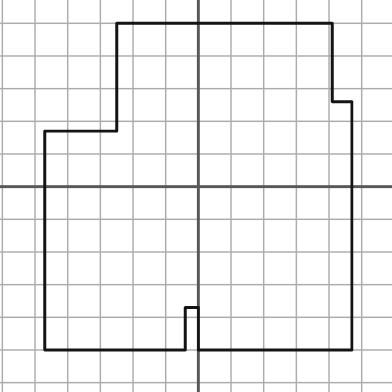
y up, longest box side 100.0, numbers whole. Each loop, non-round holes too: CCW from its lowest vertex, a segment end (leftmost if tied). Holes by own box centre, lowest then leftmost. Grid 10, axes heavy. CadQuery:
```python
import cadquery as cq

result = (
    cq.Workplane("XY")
    .moveTo(-47.0, -50.0)
    .lineTo(-4.0, -50.0)
    .lineTo(-4.0, -37.0)
    .lineTo(0.0, -37.0)
    .lineTo(0.0, -50.0)
    .lineTo(47.0, -50.0)
    .lineTo(47.0, 26.0)
    .lineTo(41.0, 26.0)
    .lineTo(41.0, 50.0)
    .lineTo(-25.0, 50.0)
    .lineTo(-25.0, 17.0)
    .lineTo(-47.0, 17.0)
    .close()
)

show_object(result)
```